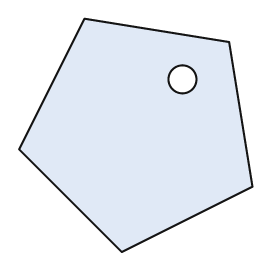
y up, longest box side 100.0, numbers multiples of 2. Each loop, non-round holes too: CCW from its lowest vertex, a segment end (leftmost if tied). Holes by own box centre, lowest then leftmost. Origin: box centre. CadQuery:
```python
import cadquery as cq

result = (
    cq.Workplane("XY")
    .moveTo(-6.0, -50.0)
    .lineTo(50.0, -22.0)
    .lineTo(40.0, 40.0)
    .lineTo(-22.0, 50.0)
    .lineTo(-50.0, -6.0)
    .close()
    .moveTo(20.0, 24.0)
    .circle(6.0)
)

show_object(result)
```